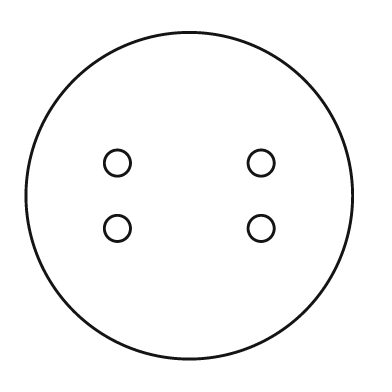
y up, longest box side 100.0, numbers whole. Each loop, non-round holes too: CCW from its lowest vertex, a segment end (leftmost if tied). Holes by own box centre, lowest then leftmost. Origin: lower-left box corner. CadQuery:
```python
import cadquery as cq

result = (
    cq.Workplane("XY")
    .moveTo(50.0, 50.0)
    .circle(50.0)
    .moveTo(28.0, 40.0)
    .circle(4.0)
    .moveTo(72.0, 40.0)
    .circle(4.0)
    .moveTo(28.0, 60.0)
    .circle(4.0)
    .moveTo(72.0, 60.0)
    .circle(4.0)
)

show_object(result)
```